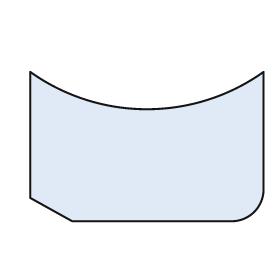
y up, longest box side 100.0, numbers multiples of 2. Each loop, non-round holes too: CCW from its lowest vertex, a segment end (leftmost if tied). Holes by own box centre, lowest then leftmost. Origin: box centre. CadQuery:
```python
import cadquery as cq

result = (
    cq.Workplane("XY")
    .moveTo(-32.0, -32.0)
    .lineTo(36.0, -32.0)
    .threePointArc((46.0, -28.0), (50.0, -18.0))
    .lineTo(50.0, 32.0)
    .threePointArc((0.0, 16.0), (-50.0, 32.0))
    .lineTo(-50.0, -22.0)
    .close()
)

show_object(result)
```